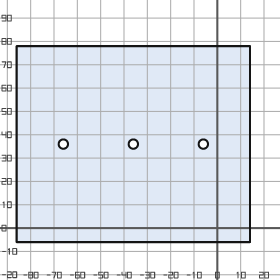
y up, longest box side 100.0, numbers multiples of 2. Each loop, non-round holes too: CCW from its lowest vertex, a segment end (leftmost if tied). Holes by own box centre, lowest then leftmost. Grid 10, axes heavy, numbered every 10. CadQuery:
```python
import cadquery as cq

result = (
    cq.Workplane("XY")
    .moveTo(-86.0, -6.0)
    .lineTo(14.0, -6.0)
    .lineTo(14.0, 78.0)
    .lineTo(-86.0, 78.0)
    .close()
    .moveTo(-66.0, 36.0)
    .circle(2.0)
    .moveTo(-36.0, 36.0)
    .circle(2.0)
    .moveTo(-6.0, 36.0)
    .circle(2.0)
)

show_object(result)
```